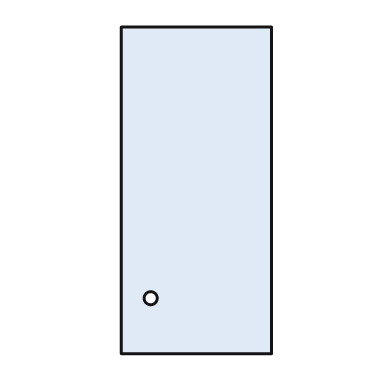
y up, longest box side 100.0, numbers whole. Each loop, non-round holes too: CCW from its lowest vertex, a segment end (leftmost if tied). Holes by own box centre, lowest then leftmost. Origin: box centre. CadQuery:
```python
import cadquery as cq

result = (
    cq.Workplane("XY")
    .moveTo(-23.0, -50.0)
    .lineTo(23.0, -50.0)
    .lineTo(23.0, 50.0)
    .lineTo(-23.0, 50.0)
    .close()
    .moveTo(-14.0, -33.0)
    .circle(2.0)
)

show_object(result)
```